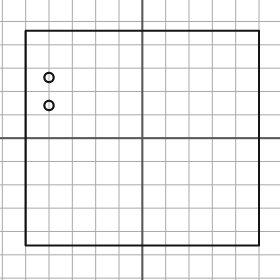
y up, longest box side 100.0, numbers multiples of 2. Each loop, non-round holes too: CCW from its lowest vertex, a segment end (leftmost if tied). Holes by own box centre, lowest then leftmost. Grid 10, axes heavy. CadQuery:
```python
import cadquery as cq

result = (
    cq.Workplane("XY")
    .moveTo(-50.0, -46.0)
    .lineTo(50.0, -46.0)
    .lineTo(50.0, 46.0)
    .lineTo(-50.0, 46.0)
    .close()
    .moveTo(-40.0, 14.0)
    .circle(2.0)
    .moveTo(-40.0, 26.0)
    .circle(2.0)
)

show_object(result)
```